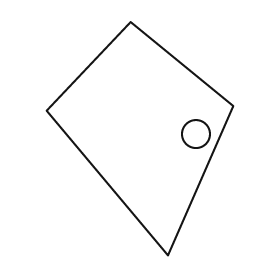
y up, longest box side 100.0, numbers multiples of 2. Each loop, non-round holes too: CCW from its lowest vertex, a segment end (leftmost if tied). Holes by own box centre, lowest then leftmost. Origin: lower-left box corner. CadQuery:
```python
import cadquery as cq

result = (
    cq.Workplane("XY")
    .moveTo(52.0, 0.0)
    .lineTo(80.0, 64.0)
    .lineTo(36.0, 100.0)
    .lineTo(0.0, 62.0)
    .close()
    .moveTo(64.0, 52.0)
    .circle(6.0)
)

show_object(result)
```